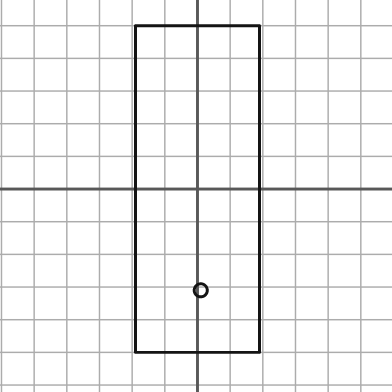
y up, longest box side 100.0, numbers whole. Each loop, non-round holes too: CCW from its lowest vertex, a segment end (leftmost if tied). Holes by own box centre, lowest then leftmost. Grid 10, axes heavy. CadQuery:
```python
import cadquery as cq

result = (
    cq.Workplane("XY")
    .moveTo(-19.0, -50.0)
    .lineTo(19.0, -50.0)
    .lineTo(19.0, 50.0)
    .lineTo(-19.0, 50.0)
    .close()
    .moveTo(1.0, -31.0)
    .circle(2.0)
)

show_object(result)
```